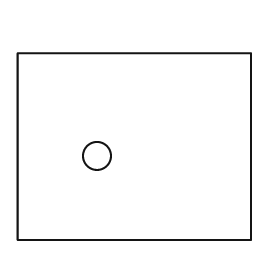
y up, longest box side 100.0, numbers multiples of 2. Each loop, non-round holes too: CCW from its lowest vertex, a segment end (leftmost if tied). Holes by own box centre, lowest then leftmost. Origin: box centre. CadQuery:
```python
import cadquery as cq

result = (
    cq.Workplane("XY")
    .moveTo(-50.0, -40.0)
    .lineTo(50.0, -40.0)
    .lineTo(50.0, 40.0)
    .lineTo(-50.0, 40.0)
    .close()
    .moveTo(-16.0, -4.0)
    .circle(6.0)
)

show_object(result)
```